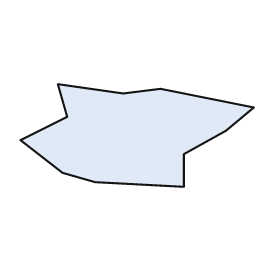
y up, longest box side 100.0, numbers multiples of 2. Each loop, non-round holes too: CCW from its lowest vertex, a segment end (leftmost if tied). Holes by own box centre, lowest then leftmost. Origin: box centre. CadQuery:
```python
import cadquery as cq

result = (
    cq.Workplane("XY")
    .moveTo(20.0, -22.0)
    .lineTo(20.0, -8.0)
    .lineTo(38.0, 2.0)
    .lineTo(50.0, 12.0)
    .lineTo(10.0, 20.0)
    .lineTo(-6.0, 18.0)
    .lineTo(-34.0, 22.0)
    .lineTo(-30.0, 8.0)
    .lineTo(-50.0, -2.0)
    .lineTo(-32.0, -16.0)
    .lineTo(-18.0, -20.0)
    .close()
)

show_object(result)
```